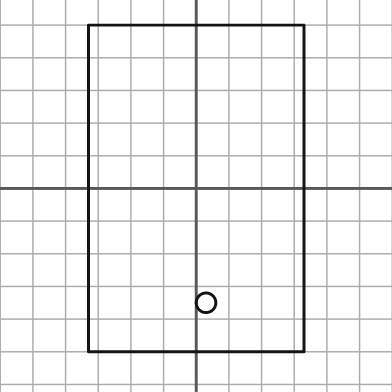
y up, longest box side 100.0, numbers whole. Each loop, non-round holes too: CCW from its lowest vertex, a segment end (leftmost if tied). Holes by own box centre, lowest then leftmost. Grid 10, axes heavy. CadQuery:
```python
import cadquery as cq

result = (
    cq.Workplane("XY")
    .moveTo(-33.0, -50.0)
    .lineTo(33.0, -50.0)
    .lineTo(33.0, 50.0)
    .lineTo(-33.0, 50.0)
    .close()
    .moveTo(3.0, -35.0)
    .circle(3.0)
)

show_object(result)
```